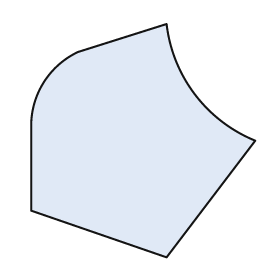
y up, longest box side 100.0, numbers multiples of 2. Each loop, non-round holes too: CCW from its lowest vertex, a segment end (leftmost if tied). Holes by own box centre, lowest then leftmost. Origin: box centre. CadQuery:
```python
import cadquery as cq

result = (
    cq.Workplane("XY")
    .moveTo(10.0, -50.0)
    .lineTo(48.0, 0.0)
    .threePointArc((22.0, 20.0), (10.0, 50.0))
    .lineTo(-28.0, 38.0)
    .threePointArc((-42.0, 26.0), (-48.0, 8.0))
    .lineTo(-48.0, -30.0)
    .close()
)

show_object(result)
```